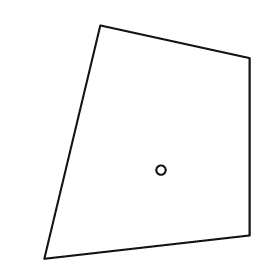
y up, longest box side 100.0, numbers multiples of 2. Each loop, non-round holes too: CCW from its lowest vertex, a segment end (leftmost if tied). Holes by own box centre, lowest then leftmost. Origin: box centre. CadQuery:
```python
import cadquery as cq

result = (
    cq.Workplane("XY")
    .moveTo(-44.0, -50.0)
    .lineTo(44.0, -40.0)
    .lineTo(44.0, 36.0)
    .lineTo(-20.0, 50.0)
    .close()
    .moveTo(6.0, -12.0)
    .circle(2.0)
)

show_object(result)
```